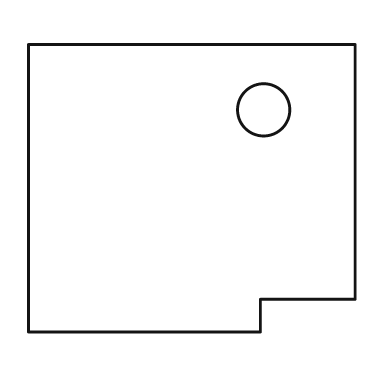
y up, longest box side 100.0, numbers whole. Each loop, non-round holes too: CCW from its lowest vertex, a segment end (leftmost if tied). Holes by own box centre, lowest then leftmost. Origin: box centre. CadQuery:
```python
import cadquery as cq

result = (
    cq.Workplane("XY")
    .moveTo(-50.0, -44.0)
    .lineTo(21.0, -44.0)
    .lineTo(21.0, -34.0)
    .lineTo(50.0, -34.0)
    .lineTo(50.0, 44.0)
    .lineTo(-50.0, 44.0)
    .close()
    .moveTo(22.0, 24.0)
    .circle(8.0)
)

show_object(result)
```